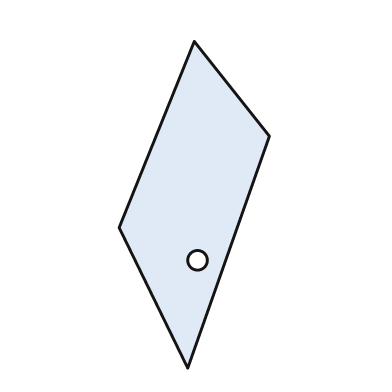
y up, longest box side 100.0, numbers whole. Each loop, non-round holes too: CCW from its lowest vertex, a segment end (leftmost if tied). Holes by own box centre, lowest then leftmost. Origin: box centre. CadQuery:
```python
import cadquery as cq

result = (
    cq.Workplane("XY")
    .moveTo(-2.0, -50.0)
    .lineTo(23.0, 21.0)
    .lineTo(0.0, 50.0)
    .lineTo(-23.0, -7.0)
    .close()
    .moveTo(1.0, -17.0)
    .circle(3.0)
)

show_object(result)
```